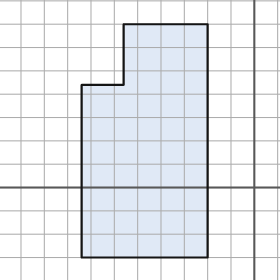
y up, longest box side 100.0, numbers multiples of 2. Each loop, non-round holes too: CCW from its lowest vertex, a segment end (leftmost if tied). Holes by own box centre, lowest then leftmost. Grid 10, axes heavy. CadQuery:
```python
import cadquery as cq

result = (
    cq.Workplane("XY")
    .moveTo(-74.0, -30.0)
    .lineTo(-20.0, -30.0)
    .lineTo(-20.0, 70.0)
    .lineTo(-56.0, 70.0)
    .lineTo(-56.0, 44.0)
    .lineTo(-74.0, 44.0)
    .close()
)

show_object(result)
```